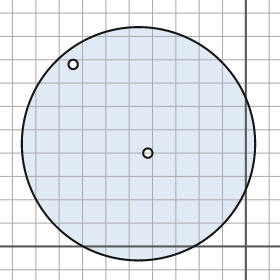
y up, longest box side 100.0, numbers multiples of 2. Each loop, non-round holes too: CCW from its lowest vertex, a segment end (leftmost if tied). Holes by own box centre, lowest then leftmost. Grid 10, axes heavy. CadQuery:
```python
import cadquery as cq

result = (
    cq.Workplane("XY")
    .moveTo(-46.0, 44.0)
    .circle(50.0)
    .moveTo(-42.0, 40.0)
    .circle(2.0)
    .moveTo(-74.0, 78.0)
    .circle(2.0)
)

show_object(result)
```